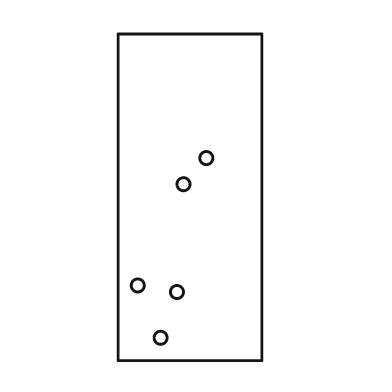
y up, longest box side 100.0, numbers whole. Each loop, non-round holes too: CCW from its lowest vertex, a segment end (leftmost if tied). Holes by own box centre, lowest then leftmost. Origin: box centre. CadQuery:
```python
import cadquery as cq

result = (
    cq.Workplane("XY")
    .moveTo(-22.0, -50.0)
    .lineTo(22.0, -50.0)
    .lineTo(22.0, 50.0)
    .lineTo(-22.0, 50.0)
    .close()
    .moveTo(-9.0, -43.0)
    .circle(2.0)
    .moveTo(-4.0, -29.0)
    .circle(2.0)
    .moveTo(-16.0, -27.0)
    .circle(2.0)
    .moveTo(-2.0, 4.0)
    .circle(2.0)
    .moveTo(5.0, 12.0)
    .circle(2.0)
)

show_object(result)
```